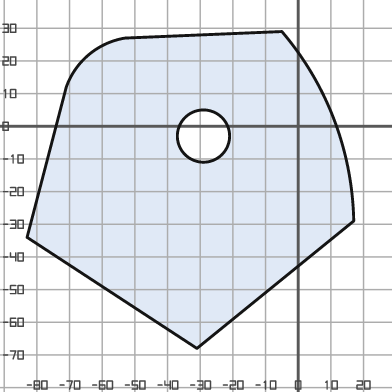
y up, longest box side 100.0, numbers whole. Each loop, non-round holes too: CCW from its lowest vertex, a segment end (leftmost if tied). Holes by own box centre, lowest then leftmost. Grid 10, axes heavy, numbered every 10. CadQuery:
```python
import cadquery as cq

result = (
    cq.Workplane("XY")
    .moveTo(-31.0, -68.0)
    .lineTo(17.0, -29.0)
    .threePointArc((11.0, 2.0), (-5.0, 29.0))
    .lineTo(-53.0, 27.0)
    .threePointArc((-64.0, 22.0), (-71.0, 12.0))
    .lineTo(-83.0, -34.0)
    .close()
    .moveTo(-29.0, -3.0)
    .circle(8.0)
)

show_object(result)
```